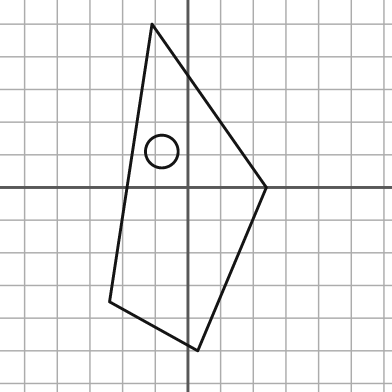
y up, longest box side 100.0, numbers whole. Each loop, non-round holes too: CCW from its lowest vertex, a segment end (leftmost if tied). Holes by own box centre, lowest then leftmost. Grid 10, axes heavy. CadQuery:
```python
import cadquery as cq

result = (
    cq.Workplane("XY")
    .moveTo(3.0, -50.0)
    .lineTo(24.0, 0.0)
    .lineTo(-11.0, 50.0)
    .lineTo(-24.0, -35.0)
    .close()
    .moveTo(-8.0, 11.0)
    .circle(5.0)
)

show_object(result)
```